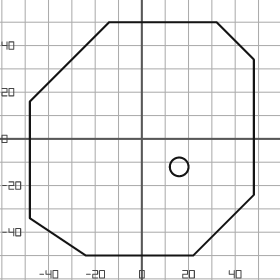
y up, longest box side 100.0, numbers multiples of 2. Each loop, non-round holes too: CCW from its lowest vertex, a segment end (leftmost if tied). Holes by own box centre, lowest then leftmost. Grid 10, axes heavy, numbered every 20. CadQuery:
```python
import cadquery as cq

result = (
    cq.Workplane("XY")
    .moveTo(-24.0, -50.0)
    .lineTo(22.0, -50.0)
    .lineTo(48.0, -24.0)
    .lineTo(48.0, 34.0)
    .lineTo(32.0, 50.0)
    .lineTo(-14.0, 50.0)
    .lineTo(-48.0, 16.0)
    .lineTo(-48.0, -34.0)
    .close()
    .moveTo(16.0, -12.0)
    .circle(4.0)
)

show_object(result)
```